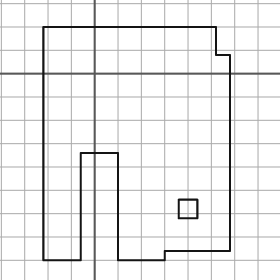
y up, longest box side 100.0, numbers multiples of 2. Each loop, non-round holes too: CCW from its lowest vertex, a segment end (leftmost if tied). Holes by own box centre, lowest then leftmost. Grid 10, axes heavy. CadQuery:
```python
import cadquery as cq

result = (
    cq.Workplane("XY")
    .moveTo(-22.0, -80.0)
    .lineTo(-6.0, -80.0)
    .lineTo(-6.0, -34.0)
    .lineTo(10.0, -34.0)
    .lineTo(10.0, -80.0)
    .lineTo(30.0, -80.0)
    .lineTo(30.0, -76.0)
    .lineTo(58.0, -76.0)
    .lineTo(58.0, 8.0)
    .lineTo(52.0, 8.0)
    .lineTo(52.0, 20.0)
    .lineTo(-22.0, 20.0)
    .close()
    .moveTo(36.0, -62.0)
    .lineTo(44.0, -62.0)
    .lineTo(44.0, -54.0)
    .lineTo(36.0, -54.0)
    .close()
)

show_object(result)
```